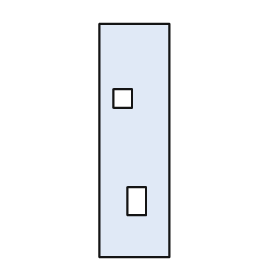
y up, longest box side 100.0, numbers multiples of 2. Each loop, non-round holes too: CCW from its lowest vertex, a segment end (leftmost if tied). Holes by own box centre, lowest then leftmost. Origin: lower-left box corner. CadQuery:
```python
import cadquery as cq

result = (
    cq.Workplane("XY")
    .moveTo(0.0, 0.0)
    .lineTo(30.0, 0.0)
    .lineTo(30.0, 100.0)
    .lineTo(0.0, 100.0)
    .close()
    .moveTo(12.0, 18.0)
    .lineTo(20.0, 18.0)
    .lineTo(20.0, 30.0)
    .lineTo(12.0, 30.0)
    .close()
    .moveTo(6.0, 64.0)
    .lineTo(14.0, 64.0)
    .lineTo(14.0, 72.0)
    .lineTo(6.0, 72.0)
    .close()
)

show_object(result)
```